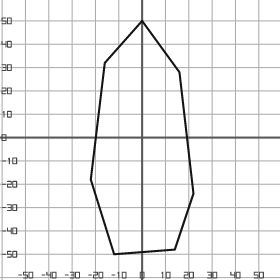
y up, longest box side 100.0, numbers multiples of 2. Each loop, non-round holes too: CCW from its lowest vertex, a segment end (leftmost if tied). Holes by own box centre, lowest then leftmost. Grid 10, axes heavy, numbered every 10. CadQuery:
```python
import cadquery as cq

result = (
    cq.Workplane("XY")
    .moveTo(-12.0, -50.0)
    .lineTo(14.0, -48.0)
    .lineTo(22.0, -24.0)
    .lineTo(16.0, 28.0)
    .lineTo(0.0, 50.0)
    .lineTo(-16.0, 32.0)
    .lineTo(-22.0, -18.0)
    .close()
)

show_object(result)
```